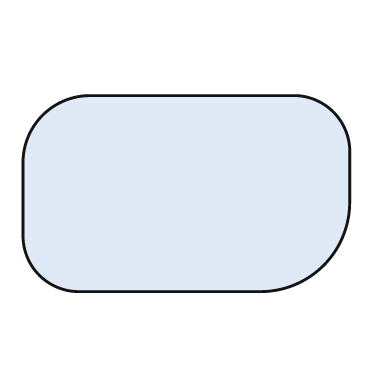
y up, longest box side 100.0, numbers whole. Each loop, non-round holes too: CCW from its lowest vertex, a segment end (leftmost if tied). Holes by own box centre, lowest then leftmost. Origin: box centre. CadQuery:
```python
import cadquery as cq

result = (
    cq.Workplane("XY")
    .moveTo(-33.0, -30.0)
    .lineTo(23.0, -30.0)
    .threePointArc((42.0, -22.0), (50.0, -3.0))
    .lineTo(50.0, 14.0)
    .threePointArc((45.0, 25.0), (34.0, 30.0))
    .lineTo(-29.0, 30.0)
    .threePointArc((-44.0, 24.0), (-50.0, 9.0))
    .lineTo(-50.0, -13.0)
    .threePointArc((-45.0, -25.0), (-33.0, -30.0))
    .close()
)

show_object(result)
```